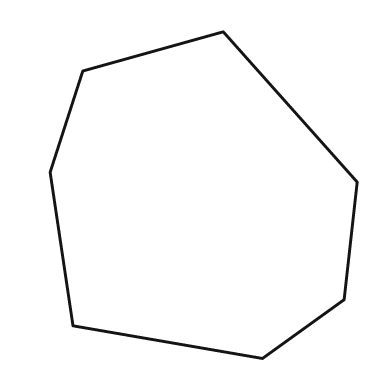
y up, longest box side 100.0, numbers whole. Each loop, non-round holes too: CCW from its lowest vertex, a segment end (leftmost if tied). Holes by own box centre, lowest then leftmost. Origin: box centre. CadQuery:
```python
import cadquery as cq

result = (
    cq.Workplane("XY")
    .moveTo(18.0, -50.0)
    .lineTo(43.0, -32.0)
    .lineTo(47.0, 4.0)
    .lineTo(6.0, 50.0)
    .lineTo(-37.0, 38.0)
    .lineTo(-47.0, 7.0)
    .lineTo(-40.0, -40.0)
    .close()
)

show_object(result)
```